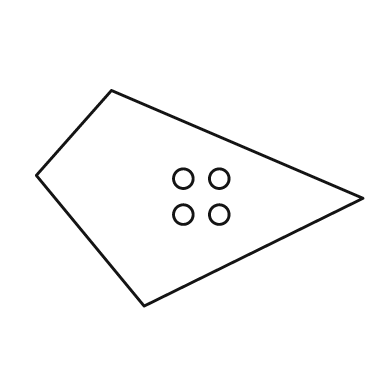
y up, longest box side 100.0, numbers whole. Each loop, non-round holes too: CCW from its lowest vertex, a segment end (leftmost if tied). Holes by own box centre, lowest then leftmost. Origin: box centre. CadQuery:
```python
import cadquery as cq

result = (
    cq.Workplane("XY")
    .moveTo(-17.0, -33.0)
    .lineTo(50.0, 0.0)
    .lineTo(-27.0, 33.0)
    .lineTo(-50.0, 7.0)
    .close()
    .moveTo(-5.0, -5.0)
    .circle(3.0)
    .moveTo(6.0, -5.0)
    .circle(3.0)
    .moveTo(-5.0, 6.0)
    .circle(3.0)
    .moveTo(6.0, 6.0)
    .circle(3.0)
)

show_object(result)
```